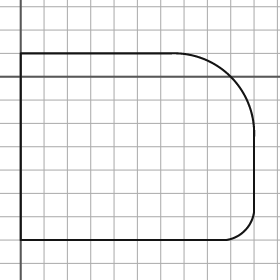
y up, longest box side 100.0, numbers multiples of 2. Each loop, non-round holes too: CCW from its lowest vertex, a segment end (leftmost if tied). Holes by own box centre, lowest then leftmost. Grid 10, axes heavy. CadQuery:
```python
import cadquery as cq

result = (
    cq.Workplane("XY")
    .moveTo(0.0, -70.0)
    .lineTo(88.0, -70.0)
    .threePointArc((96.0, -66.0), (100.0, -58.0))
    .lineTo(100.0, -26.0)
    .threePointArc((90.0, 0.0), (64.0, 10.0))
    .lineTo(0.0, 10.0)
    .close()
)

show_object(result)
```